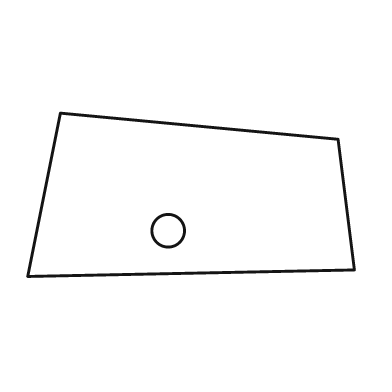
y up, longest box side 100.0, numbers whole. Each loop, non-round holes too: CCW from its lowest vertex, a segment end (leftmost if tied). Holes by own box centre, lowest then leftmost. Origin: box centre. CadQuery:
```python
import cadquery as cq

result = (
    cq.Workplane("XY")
    .moveTo(-50.0, -25.0)
    .lineTo(50.0, -23.0)
    .lineTo(45.0, 17.0)
    .lineTo(-40.0, 25.0)
    .close()
    .moveTo(-7.0, -11.0)
    .circle(5.0)
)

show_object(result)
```